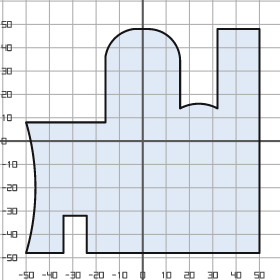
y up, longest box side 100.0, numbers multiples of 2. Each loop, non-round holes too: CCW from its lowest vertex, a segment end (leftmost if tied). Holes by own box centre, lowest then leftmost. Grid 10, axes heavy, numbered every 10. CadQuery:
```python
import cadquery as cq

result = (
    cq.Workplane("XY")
    .moveTo(-50.0, -48.0)
    .lineTo(-34.0, -48.0)
    .lineTo(-34.0, -32.0)
    .lineTo(-24.0, -32.0)
    .lineTo(-24.0, -48.0)
    .lineTo(50.0, -48.0)
    .lineTo(50.0, 48.0)
    .lineTo(32.0, 48.0)
    .lineTo(32.0, 14.0)
    .threePointArc((24.0, 16.0), (16.0, 14.0))
    .lineTo(16.0, 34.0)
    .threePointArc((12.0, 44.0), (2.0, 48.0))
    .lineTo(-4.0, 48.0)
    .threePointArc((-12.0, 44.0), (-16.0, 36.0))
    .lineTo(-16.0, 8.0)
    .lineTo(-50.0, 8.0)
    .threePointArc((-46.0, -20.0), (-50.0, -48.0))
    .close()
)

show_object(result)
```